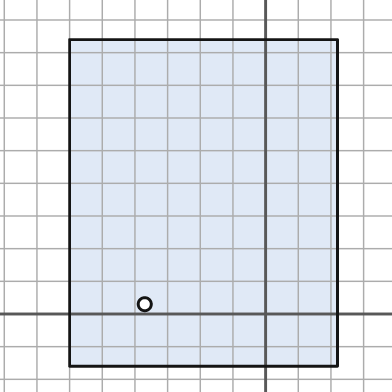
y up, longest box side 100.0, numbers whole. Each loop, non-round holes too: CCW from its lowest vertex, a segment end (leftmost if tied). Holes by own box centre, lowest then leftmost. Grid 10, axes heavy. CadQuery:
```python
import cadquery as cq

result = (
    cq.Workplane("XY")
    .moveTo(-60.0, -16.0)
    .lineTo(22.0, -16.0)
    .lineTo(22.0, 84.0)
    .lineTo(-60.0, 84.0)
    .close()
    .moveTo(-37.0, 3.0)
    .circle(2.0)
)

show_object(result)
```